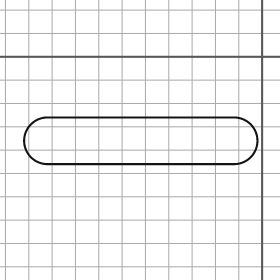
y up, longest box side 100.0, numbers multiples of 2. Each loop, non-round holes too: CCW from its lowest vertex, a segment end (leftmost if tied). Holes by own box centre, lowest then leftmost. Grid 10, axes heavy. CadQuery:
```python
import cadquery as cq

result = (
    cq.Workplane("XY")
    .moveTo(-92.0, -46.0)
    .lineTo(-12.0, -46.0)
    .threePointArc((-2.0, -36.0), (-12.0, -26.0))
    .lineTo(-92.0, -26.0)
    .threePointArc((-102.0, -36.0), (-92.0, -46.0))
    .close()
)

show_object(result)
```